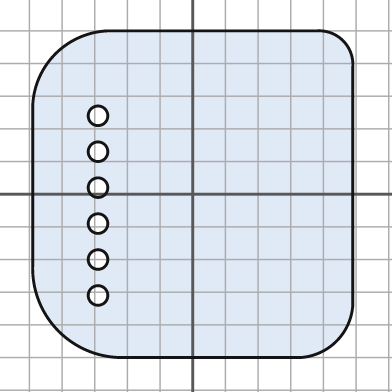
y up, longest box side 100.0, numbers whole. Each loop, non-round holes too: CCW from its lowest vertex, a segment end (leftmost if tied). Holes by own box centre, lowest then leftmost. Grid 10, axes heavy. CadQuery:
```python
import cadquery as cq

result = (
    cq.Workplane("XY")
    .moveTo(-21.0, -50.0)
    .lineTo(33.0, -50.0)
    .threePointArc((44.0, -45.0), (49.0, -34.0))
    .lineTo(49.0, 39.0)
    .threePointArc((46.0, 47.0), (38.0, 50.0))
    .lineTo(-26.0, 50.0)
    .threePointArc((-42.0, 43.0), (-49.0, 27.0))
    .lineTo(-49.0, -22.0)
    .threePointArc((-41.0, -42.0), (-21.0, -50.0))
    .close()
    .moveTo(-29.0, -31.0)
    .circle(3.0)
    .moveTo(-29.0, -20.0)
    .circle(3.0)
    .moveTo(-29.0, -9.0)
    .circle(3.0)
    .moveTo(-29.0, 2.0)
    .circle(3.0)
    .moveTo(-29.0, 13.0)
    .circle(3.0)
    .moveTo(-29.0, 24.0)
    .circle(3.0)
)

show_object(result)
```